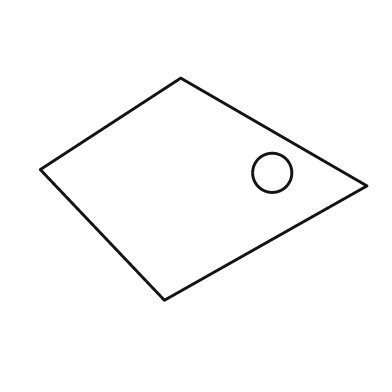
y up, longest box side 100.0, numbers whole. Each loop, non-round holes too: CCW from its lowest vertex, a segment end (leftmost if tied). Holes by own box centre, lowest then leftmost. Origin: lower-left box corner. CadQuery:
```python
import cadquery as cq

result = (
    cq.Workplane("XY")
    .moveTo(38.0, 0.0)
    .lineTo(100.0, 35.0)
    .lineTo(43.0, 68.0)
    .lineTo(0.0, 40.0)
    .close()
    .moveTo(71.0, 39.0)
    .circle(6.0)
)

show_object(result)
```